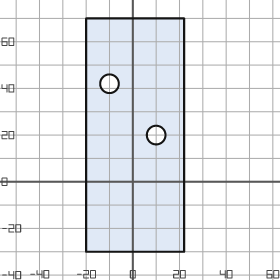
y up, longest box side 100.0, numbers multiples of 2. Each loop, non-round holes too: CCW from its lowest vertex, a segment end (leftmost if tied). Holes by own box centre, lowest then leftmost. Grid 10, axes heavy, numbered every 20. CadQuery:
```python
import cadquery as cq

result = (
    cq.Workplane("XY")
    .moveTo(-20.0, -30.0)
    .lineTo(22.0, -30.0)
    .lineTo(22.0, 70.0)
    .lineTo(-20.0, 70.0)
    .close()
    .moveTo(10.0, 20.0)
    .circle(4.0)
    .moveTo(-10.0, 42.0)
    .circle(4.0)
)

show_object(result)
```